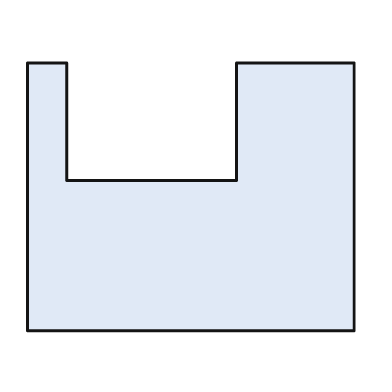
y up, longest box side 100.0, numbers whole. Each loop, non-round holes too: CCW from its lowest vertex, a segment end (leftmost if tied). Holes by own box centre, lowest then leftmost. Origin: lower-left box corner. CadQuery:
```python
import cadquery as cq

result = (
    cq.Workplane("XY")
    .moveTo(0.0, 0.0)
    .lineTo(100.0, 0.0)
    .lineTo(100.0, 82.0)
    .lineTo(64.0, 82.0)
    .lineTo(64.0, 46.0)
    .lineTo(12.0, 46.0)
    .lineTo(12.0, 82.0)
    .lineTo(0.0, 82.0)
    .close()
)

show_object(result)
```